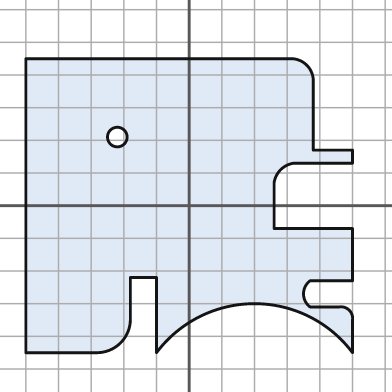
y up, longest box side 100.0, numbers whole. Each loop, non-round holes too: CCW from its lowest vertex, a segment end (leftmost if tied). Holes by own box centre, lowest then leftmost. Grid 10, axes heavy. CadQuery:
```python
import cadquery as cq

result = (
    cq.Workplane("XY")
    .moveTo(-50.0, -45.0)
    .lineTo(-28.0, -45.0)
    .threePointArc((-21.0, -42.0), (-18.0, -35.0))
    .lineTo(-18.0, -22.0)
    .lineTo(-10.0, -22.0)
    .lineTo(-10.0, -45.0)
    .threePointArc((20.0, -30.0), (50.0, -45.0))
    .lineTo(50.0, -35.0)
    .threePointArc((49.0, -32.0), (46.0, -31.0))
    .lineTo(37.0, -31.0)
    .threePointArc((35.0, -27.0), (37.0, -23.0))
    .lineTo(50.0, -23.0)
    .lineTo(50.0, -7.0)
    .lineTo(26.0, -7.0)
    .lineTo(26.0, 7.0)
    .threePointArc((28.0, 11.0), (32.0, 13.0))
    .lineTo(50.0, 13.0)
    .lineTo(50.0, 17.0)
    .lineTo(38.0, 17.0)
    .lineTo(38.0, 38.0)
    .threePointArc((36.0, 43.0), (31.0, 45.0))
    .lineTo(-50.0, 45.0)
    .close()
    .moveTo(-22.0, 21.0)
    .circle(3.0)
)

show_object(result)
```